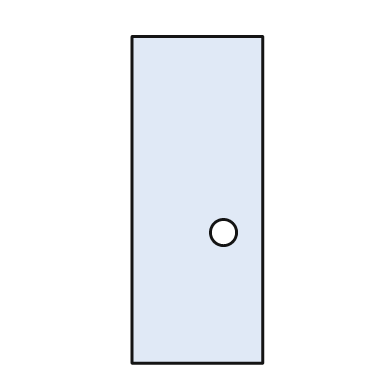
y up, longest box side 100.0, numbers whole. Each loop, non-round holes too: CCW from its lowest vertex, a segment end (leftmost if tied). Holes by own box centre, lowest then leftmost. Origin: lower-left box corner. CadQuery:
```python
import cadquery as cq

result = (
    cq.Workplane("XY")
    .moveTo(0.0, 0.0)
    .lineTo(40.0, 0.0)
    .lineTo(40.0, 100.0)
    .lineTo(0.0, 100.0)
    .close()
    .moveTo(28.0, 40.0)
    .circle(4.0)
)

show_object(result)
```